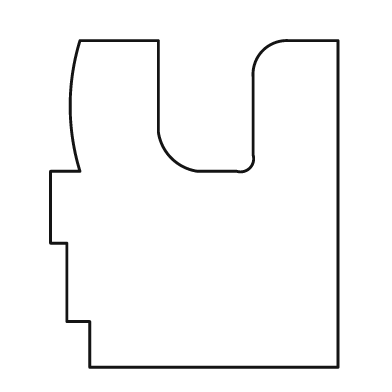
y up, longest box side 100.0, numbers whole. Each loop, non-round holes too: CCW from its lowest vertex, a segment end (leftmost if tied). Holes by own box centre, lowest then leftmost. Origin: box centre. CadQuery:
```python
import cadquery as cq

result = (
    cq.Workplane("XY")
    .moveTo(-32.0, -50.0)
    .lineTo(44.0, -50.0)
    .lineTo(44.0, 50.0)
    .lineTo(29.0, 50.0)
    .threePointArc((21.0, 47.0), (18.0, 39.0))
    .lineTo(18.0, 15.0)
    .threePointArc((17.0, 11.0), (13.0, 10.0))
    .lineTo(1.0, 10.0)
    .threePointArc((-7.0, 14.0), (-11.0, 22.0))
    .lineTo(-11.0, 50.0)
    .lineTo(-35.0, 50.0)
    .threePointArc((-38.0, 30.0), (-35.0, 10.0))
    .lineTo(-44.0, 10.0)
    .lineTo(-44.0, -12.0)
    .lineTo(-39.0, -12.0)
    .lineTo(-39.0, -36.0)
    .lineTo(-32.0, -36.0)
    .close()
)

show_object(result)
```